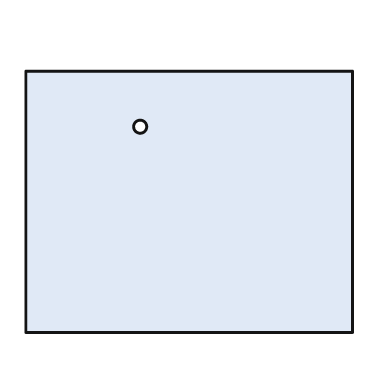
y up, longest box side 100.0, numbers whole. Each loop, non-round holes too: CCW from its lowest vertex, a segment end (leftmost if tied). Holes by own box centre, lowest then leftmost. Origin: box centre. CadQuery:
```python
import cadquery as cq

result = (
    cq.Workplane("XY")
    .moveTo(-50.0, -40.0)
    .lineTo(50.0, -40.0)
    .lineTo(50.0, 40.0)
    .lineTo(-50.0, 40.0)
    .close()
    .moveTo(-15.0, 23.0)
    .circle(2.0)
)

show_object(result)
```